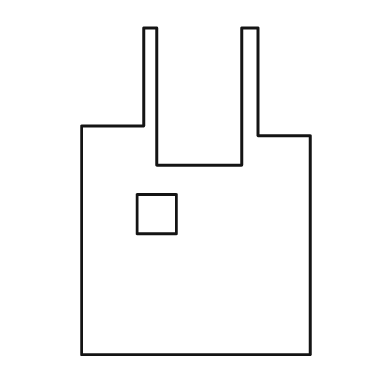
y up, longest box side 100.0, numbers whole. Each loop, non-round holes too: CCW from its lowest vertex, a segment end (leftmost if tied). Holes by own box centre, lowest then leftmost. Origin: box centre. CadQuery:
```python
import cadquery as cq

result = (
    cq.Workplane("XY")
    .moveTo(-35.0, -50.0)
    .lineTo(35.0, -50.0)
    .lineTo(35.0, 17.0)
    .lineTo(19.0, 17.0)
    .lineTo(19.0, 50.0)
    .lineTo(14.0, 50.0)
    .lineTo(14.0, 8.0)
    .lineTo(-12.0, 8.0)
    .lineTo(-12.0, 50.0)
    .lineTo(-16.0, 50.0)
    .lineTo(-16.0, 20.0)
    .lineTo(-35.0, 20.0)
    .close()
    .moveTo(-18.0, -13.0)
    .lineTo(-6.0, -13.0)
    .lineTo(-6.0, -1.0)
    .lineTo(-18.0, -1.0)
    .close()
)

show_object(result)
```